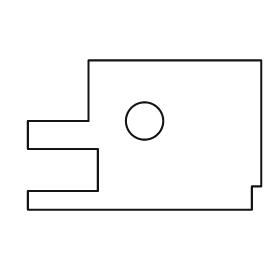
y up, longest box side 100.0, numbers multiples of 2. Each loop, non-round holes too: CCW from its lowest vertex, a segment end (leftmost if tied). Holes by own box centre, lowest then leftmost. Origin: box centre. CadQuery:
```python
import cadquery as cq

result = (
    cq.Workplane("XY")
    .moveTo(-50.0, -32.0)
    .lineTo(46.0, -32.0)
    .lineTo(46.0, -22.0)
    .lineTo(50.0, -22.0)
    .lineTo(50.0, 32.0)
    .lineTo(-24.0, 32.0)
    .lineTo(-24.0, 6.0)
    .lineTo(-50.0, 6.0)
    .lineTo(-50.0, -6.0)
    .lineTo(-20.0, -6.0)
    .lineTo(-20.0, -24.0)
    .lineTo(-50.0, -24.0)
    .close()
    .moveTo(0.0, 6.0)
    .circle(8.0)
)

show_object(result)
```